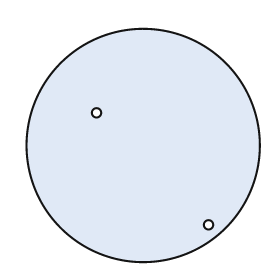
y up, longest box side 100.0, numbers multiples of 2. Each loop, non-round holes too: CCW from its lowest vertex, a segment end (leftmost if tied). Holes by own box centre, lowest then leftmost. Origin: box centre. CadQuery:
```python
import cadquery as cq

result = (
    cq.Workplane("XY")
    .moveTo(0.0, 0.0)
    .circle(50.0)
    .moveTo(28.0, -34.0)
    .circle(2.0)
    .moveTo(-20.0, 14.0)
    .circle(2.0)
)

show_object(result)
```